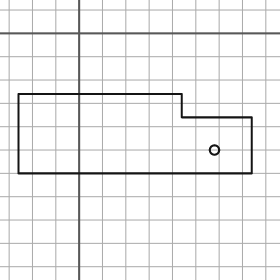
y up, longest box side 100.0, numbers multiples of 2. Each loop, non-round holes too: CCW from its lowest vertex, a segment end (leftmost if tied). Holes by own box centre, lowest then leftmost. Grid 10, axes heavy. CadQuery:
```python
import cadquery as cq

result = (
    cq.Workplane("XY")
    .moveTo(-26.0, -60.0)
    .lineTo(74.0, -60.0)
    .lineTo(74.0, -36.0)
    .lineTo(44.0, -36.0)
    .lineTo(44.0, -26.0)
    .lineTo(-26.0, -26.0)
    .close()
    .moveTo(58.0, -50.0)
    .circle(2.0)
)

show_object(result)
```